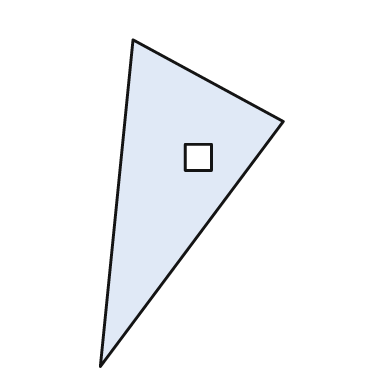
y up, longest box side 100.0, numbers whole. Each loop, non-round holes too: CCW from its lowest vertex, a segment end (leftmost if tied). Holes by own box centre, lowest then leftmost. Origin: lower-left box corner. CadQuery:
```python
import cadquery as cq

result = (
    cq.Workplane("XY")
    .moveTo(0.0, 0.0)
    .lineTo(56.0, 75.0)
    .lineTo(10.0, 100.0)
    .close()
    .moveTo(26.0, 60.0)
    .lineTo(34.0, 60.0)
    .lineTo(34.0, 68.0)
    .lineTo(26.0, 68.0)
    .close()
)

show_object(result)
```